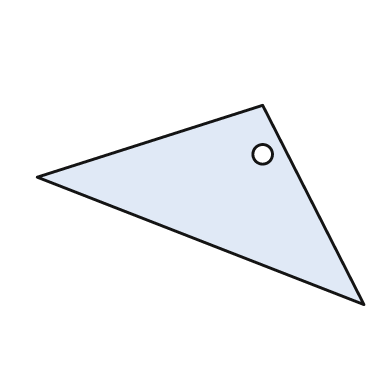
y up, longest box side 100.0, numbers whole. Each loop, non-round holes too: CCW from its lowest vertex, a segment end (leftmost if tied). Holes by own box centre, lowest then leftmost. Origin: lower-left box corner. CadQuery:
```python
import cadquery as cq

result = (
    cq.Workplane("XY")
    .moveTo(100.0, 0.0)
    .lineTo(69.0, 61.0)
    .lineTo(0.0, 39.0)
    .close()
    .moveTo(69.0, 46.0)
    .circle(3.0)
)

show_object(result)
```